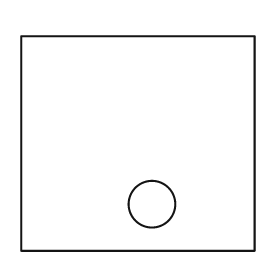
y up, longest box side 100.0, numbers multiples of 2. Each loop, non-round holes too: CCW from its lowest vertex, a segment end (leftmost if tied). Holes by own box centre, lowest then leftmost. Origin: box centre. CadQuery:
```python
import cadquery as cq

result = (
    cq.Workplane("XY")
    .moveTo(-50.0, -46.0)
    .lineTo(50.0, -46.0)
    .lineTo(50.0, 46.0)
    .lineTo(-50.0, 46.0)
    .close()
    .moveTo(6.0, -26.0)
    .circle(10.0)
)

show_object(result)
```